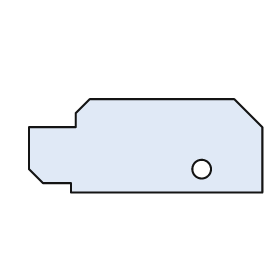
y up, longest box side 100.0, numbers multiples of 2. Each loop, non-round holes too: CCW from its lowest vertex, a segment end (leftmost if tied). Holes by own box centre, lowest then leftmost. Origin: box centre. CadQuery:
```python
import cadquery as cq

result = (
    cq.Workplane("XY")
    .moveTo(-32.0, -20.0)
    .lineTo(50.0, -20.0)
    .lineTo(50.0, 8.0)
    .lineTo(38.0, 20.0)
    .lineTo(-24.0, 20.0)
    .lineTo(-30.0, 14.0)
    .lineTo(-30.0, 8.0)
    .lineTo(-50.0, 8.0)
    .lineTo(-50.0, -10.0)
    .lineTo(-44.0, -16.0)
    .lineTo(-32.0, -16.0)
    .close()
    .moveTo(24.0, -10.0)
    .circle(4.0)
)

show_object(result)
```